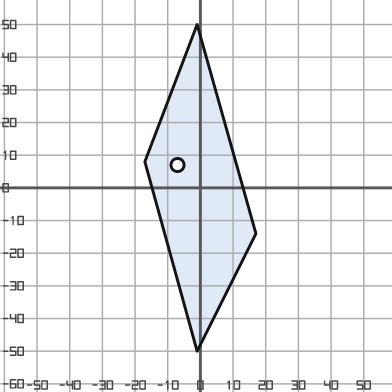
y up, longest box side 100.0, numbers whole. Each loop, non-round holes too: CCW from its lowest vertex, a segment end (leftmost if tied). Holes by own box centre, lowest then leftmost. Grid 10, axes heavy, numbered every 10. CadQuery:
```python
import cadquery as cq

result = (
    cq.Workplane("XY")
    .moveTo(-1.0, -50.0)
    .lineTo(17.0, -14.0)
    .lineTo(-1.0, 50.0)
    .lineTo(-17.0, 8.0)
    .close()
    .moveTo(-7.0, 7.0)
    .circle(2.0)
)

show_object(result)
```